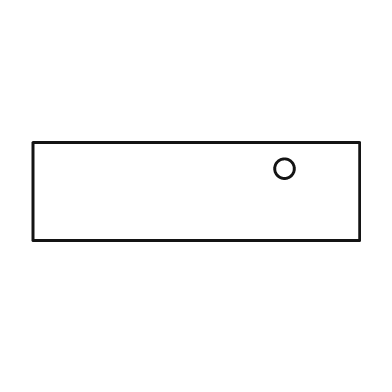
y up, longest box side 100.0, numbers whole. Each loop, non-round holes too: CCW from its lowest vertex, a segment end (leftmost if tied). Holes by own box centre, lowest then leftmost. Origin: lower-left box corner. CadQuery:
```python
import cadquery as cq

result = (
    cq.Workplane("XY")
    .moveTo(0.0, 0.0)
    .lineTo(100.0, 0.0)
    .lineTo(100.0, 30.0)
    .lineTo(0.0, 30.0)
    .close()
    .moveTo(77.0, 22.0)
    .circle(3.0)
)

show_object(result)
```